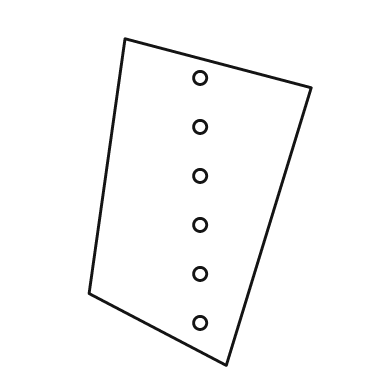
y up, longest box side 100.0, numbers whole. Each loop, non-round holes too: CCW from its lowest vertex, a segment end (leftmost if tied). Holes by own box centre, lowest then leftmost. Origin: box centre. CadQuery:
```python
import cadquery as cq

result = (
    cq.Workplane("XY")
    .moveTo(8.0, -50.0)
    .lineTo(34.0, 35.0)
    .lineTo(-23.0, 50.0)
    .lineTo(-34.0, -28.0)
    .close()
    .moveTo(0.0, -37.0)
    .circle(2.0)
    .moveTo(0.0, -22.0)
    .circle(2.0)
    .moveTo(0.0, -7.0)
    .circle(2.0)
    .moveTo(0.0, 8.0)
    .circle(2.0)
    .moveTo(0.0, 23.0)
    .circle(2.0)
    .moveTo(0.0, 38.0)
    .circle(2.0)
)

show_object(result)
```